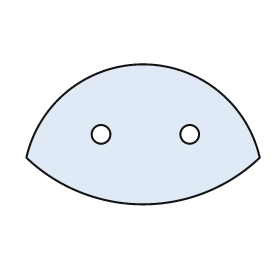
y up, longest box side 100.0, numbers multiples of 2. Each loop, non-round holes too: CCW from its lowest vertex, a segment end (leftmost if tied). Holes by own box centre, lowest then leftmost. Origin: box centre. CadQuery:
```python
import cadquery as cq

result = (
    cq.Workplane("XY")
    .moveTo(-50.0, -10.0)
    .threePointArc((0.0, -30.0), (50.0, -10.0))
    .threePointArc((0.0, 30.0), (-50.0, -10.0))
    .close()
    .moveTo(-18.0, 0.0)
    .circle(4.0)
    .moveTo(20.0, 0.0)
    .circle(4.0)
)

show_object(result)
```